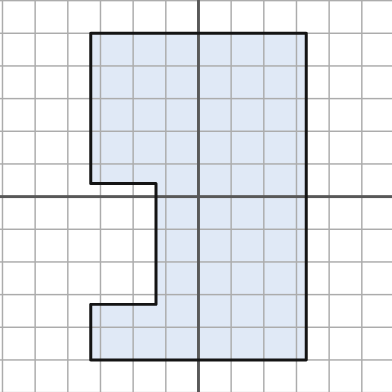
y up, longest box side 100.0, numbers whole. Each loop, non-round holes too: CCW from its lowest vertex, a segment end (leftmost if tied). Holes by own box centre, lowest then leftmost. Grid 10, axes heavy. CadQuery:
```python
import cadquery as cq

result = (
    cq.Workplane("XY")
    .moveTo(-33.0, -50.0)
    .lineTo(33.0, -50.0)
    .lineTo(33.0, 50.0)
    .lineTo(-33.0, 50.0)
    .lineTo(-33.0, 4.0)
    .lineTo(-13.0, 4.0)
    .lineTo(-13.0, -33.0)
    .lineTo(-33.0, -33.0)
    .close()
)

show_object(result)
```